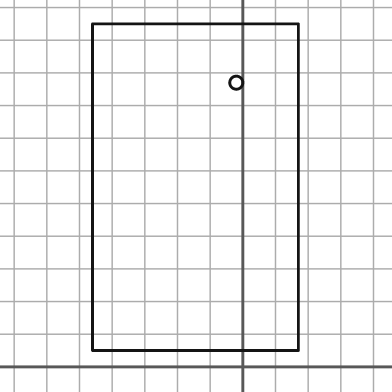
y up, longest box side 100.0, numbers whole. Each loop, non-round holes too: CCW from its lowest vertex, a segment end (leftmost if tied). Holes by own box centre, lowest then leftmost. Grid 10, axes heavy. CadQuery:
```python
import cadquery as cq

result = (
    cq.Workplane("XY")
    .moveTo(-46.0, 5.0)
    .lineTo(17.0, 5.0)
    .lineTo(17.0, 105.0)
    .lineTo(-46.0, 105.0)
    .close()
    .moveTo(-2.0, 87.0)
    .circle(2.0)
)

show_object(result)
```